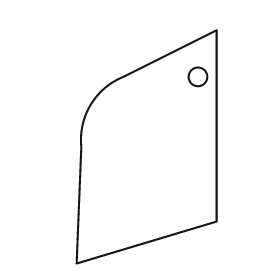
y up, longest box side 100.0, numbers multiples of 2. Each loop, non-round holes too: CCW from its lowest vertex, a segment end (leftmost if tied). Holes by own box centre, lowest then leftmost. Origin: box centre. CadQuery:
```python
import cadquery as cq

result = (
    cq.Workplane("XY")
    .moveTo(-30.0, -50.0)
    .lineTo(30.0, -32.0)
    .lineTo(30.0, 50.0)
    .lineTo(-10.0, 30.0)
    .threePointArc((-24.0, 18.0), (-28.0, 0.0))
    .close()
    .moveTo(22.0, 30.0)
    .circle(4.0)
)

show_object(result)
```